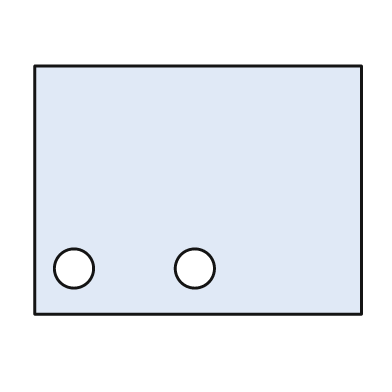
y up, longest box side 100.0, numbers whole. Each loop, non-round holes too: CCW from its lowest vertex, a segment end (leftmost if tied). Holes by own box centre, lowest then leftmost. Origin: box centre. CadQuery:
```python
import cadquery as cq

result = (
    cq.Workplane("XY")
    .moveTo(-50.0, -38.0)
    .lineTo(50.0, -38.0)
    .lineTo(50.0, 38.0)
    .lineTo(-50.0, 38.0)
    .close()
    .moveTo(-38.0, -24.0)
    .circle(6.0)
    .moveTo(-1.0, -24.0)
    .circle(6.0)
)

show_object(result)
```